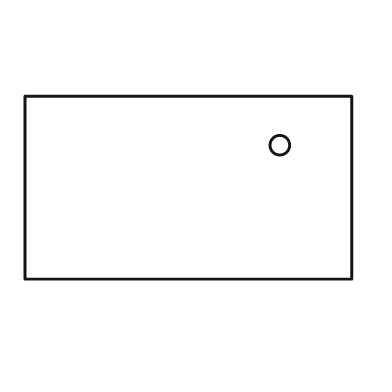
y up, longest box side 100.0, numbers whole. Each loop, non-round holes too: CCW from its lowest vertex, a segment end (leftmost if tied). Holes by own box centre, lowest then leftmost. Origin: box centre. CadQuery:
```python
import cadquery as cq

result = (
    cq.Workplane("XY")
    .moveTo(-50.0, -28.0)
    .lineTo(50.0, -28.0)
    .lineTo(50.0, 28.0)
    .lineTo(-50.0, 28.0)
    .close()
    .moveTo(28.0, 13.0)
    .circle(3.0)
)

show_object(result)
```